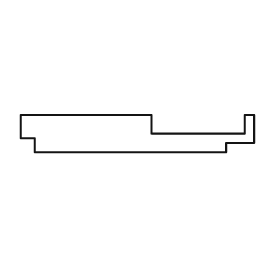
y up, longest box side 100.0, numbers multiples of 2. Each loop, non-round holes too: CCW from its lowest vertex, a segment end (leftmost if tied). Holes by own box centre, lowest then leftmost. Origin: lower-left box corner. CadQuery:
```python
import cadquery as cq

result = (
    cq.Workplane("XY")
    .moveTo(6.0, 0.0)
    .lineTo(88.0, 0.0)
    .lineTo(88.0, 4.0)
    .lineTo(100.0, 4.0)
    .lineTo(100.0, 16.0)
    .lineTo(96.0, 16.0)
    .lineTo(96.0, 8.0)
    .lineTo(56.0, 8.0)
    .lineTo(56.0, 16.0)
    .lineTo(0.0, 16.0)
    .lineTo(0.0, 6.0)
    .lineTo(6.0, 6.0)
    .close()
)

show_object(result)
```